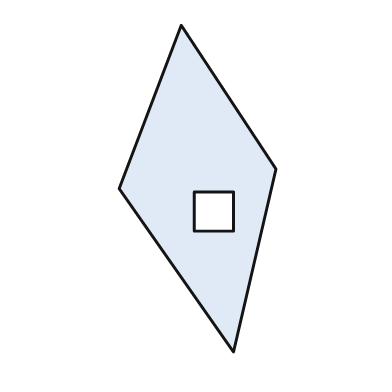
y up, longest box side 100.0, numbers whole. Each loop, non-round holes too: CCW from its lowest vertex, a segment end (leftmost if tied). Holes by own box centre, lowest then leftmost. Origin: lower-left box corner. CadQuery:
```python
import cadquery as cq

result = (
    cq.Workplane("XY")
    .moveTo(35.0, 0.0)
    .lineTo(48.0, 56.0)
    .lineTo(19.0, 100.0)
    .lineTo(0.0, 50.0)
    .close()
    .moveTo(23.0, 37.0)
    .lineTo(35.0, 37.0)
    .lineTo(35.0, 49.0)
    .lineTo(23.0, 49.0)
    .close()
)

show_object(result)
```